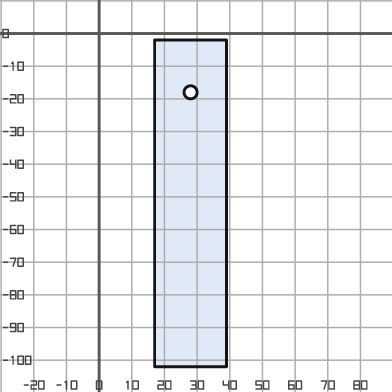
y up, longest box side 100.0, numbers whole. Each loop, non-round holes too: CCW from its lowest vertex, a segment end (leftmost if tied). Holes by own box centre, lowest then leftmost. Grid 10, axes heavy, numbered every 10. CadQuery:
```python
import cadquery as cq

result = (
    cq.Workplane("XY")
    .moveTo(17.0, -102.0)
    .lineTo(39.0, -102.0)
    .lineTo(39.0, -2.0)
    .lineTo(17.0, -2.0)
    .close()
    .moveTo(28.0, -18.0)
    .circle(2.0)
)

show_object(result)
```